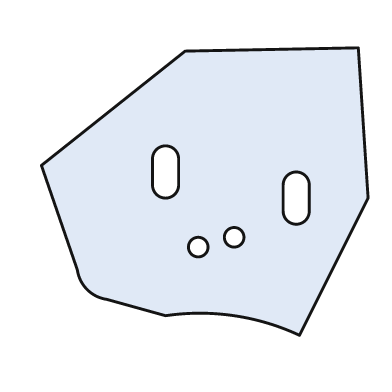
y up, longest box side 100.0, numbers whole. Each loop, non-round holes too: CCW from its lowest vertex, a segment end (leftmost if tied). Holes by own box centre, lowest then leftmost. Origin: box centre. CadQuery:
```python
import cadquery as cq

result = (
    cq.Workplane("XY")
    .moveTo(29.0, -44.0)
    .lineTo(50.0, -2.0)
    .lineTo(47.0, 44.0)
    .lineTo(-6.0, 43.0)
    .lineTo(-50.0, 8.0)
    .lineTo(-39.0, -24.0)
    .threePointArc((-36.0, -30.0), (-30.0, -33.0))
    .lineTo(-12.0, -38.0)
    .threePointArc((9.0, -38.0), (29.0, -44.0))
    .close()
    .moveTo(-2.0, -17.0)
    .circle(3.0)
    .moveTo(9.0, -14.0)
    .circle(3.0)
    .moveTo(24.0, -6.0)
    .threePointArc((28.0, -10.0), (32.0, -6.0))
    .lineTo(32.0, 2.0)
    .threePointArc((28.0, 6.0), (24.0, 2.0))
    .close()
    .moveTo(-16.0, 2.0)
    .threePointArc((-12.0, -2.0), (-8.0, 2.0))
    .lineTo(-8.0, 10.0)
    .threePointArc((-12.0, 14.0), (-16.0, 10.0))
    .close()
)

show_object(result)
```